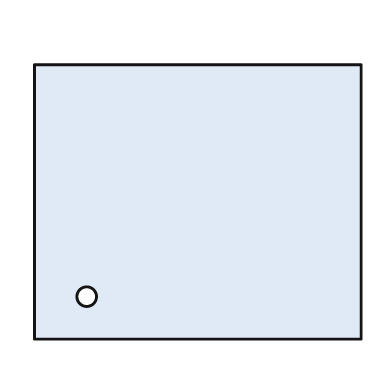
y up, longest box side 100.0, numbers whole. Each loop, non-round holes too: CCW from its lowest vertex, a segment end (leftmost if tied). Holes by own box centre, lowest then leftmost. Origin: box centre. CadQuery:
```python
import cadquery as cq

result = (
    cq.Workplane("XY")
    .moveTo(-50.0, -42.0)
    .lineTo(50.0, -42.0)
    .lineTo(50.0, 42.0)
    .lineTo(-50.0, 42.0)
    .close()
    .moveTo(-34.0, -29.0)
    .circle(3.0)
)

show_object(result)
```